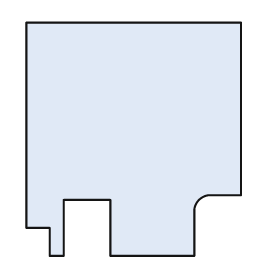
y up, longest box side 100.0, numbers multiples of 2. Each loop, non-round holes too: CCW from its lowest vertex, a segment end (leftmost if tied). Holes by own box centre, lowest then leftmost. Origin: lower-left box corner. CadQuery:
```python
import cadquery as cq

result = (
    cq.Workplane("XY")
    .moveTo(10.0, 0.0)
    .lineTo(16.0, 0.0)
    .lineTo(16.0, 24.0)
    .lineTo(36.0, 24.0)
    .lineTo(36.0, 0.0)
    .lineTo(72.0, 0.0)
    .lineTo(72.0, 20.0)
    .threePointArc((74.0, 24.0), (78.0, 26.0))
    .lineTo(92.0, 26.0)
    .lineTo(92.0, 100.0)
    .lineTo(0.0, 100.0)
    .lineTo(0.0, 12.0)
    .lineTo(10.0, 12.0)
    .close()
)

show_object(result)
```